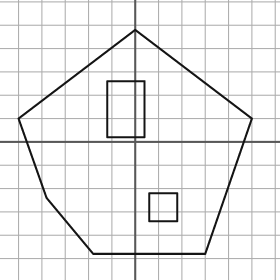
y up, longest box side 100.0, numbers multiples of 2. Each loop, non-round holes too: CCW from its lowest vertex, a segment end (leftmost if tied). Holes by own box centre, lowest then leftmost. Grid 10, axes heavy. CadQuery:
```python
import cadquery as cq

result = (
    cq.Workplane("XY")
    .moveTo(-18.0, -48.0)
    .lineTo(30.0, -48.0)
    .lineTo(50.0, 10.0)
    .lineTo(0.0, 48.0)
    .lineTo(-50.0, 10.0)
    .lineTo(-38.0, -24.0)
    .close()
    .moveTo(6.0, -34.0)
    .lineTo(18.0, -34.0)
    .lineTo(18.0, -22.0)
    .lineTo(6.0, -22.0)
    .close()
    .moveTo(-12.0, 2.0)
    .lineTo(4.0, 2.0)
    .lineTo(4.0, 26.0)
    .lineTo(-12.0, 26.0)
    .close()
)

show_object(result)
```